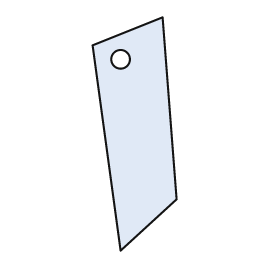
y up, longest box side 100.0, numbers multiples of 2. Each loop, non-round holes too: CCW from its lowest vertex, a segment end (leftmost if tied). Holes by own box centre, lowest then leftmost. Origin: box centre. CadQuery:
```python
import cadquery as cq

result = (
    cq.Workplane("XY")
    .moveTo(-6.0, -50.0)
    .lineTo(18.0, -28.0)
    .lineTo(12.0, 50.0)
    .lineTo(-18.0, 38.0)
    .close()
    .moveTo(-6.0, 32.0)
    .circle(4.0)
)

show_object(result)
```